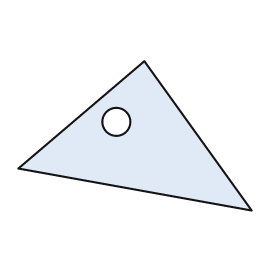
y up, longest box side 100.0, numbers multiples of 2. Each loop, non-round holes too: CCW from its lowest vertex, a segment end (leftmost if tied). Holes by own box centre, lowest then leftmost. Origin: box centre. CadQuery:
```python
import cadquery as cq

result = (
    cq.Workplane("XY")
    .moveTo(50.0, -32.0)
    .lineTo(4.0, 32.0)
    .lineTo(-50.0, -14.0)
    .close()
    .moveTo(-8.0, 6.0)
    .circle(6.0)
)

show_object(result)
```